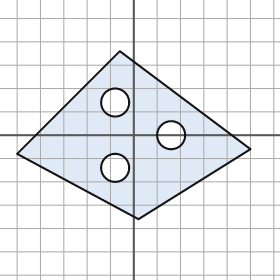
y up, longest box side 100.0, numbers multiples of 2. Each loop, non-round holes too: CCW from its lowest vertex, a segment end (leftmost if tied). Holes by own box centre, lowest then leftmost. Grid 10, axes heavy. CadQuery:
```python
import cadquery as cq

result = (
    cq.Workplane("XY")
    .moveTo(2.0, -36.0)
    .lineTo(50.0, -6.0)
    .lineTo(-6.0, 36.0)
    .lineTo(-50.0, -8.0)
    .close()
    .moveTo(-8.0, -14.0)
    .circle(6.0)
    .moveTo(16.0, 0.0)
    .circle(6.0)
    .moveTo(-8.0, 14.0)
    .circle(6.0)
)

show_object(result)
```